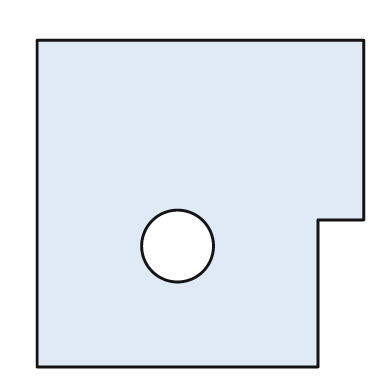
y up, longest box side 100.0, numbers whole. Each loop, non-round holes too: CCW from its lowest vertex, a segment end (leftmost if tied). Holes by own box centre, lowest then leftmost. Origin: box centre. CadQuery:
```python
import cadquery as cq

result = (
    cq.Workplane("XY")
    .moveTo(-50.0, -50.0)
    .lineTo(36.0, -50.0)
    .lineTo(36.0, -5.0)
    .lineTo(50.0, -5.0)
    .lineTo(50.0, 50.0)
    .lineTo(-50.0, 50.0)
    .close()
    .moveTo(-7.0, -13.0)
    .circle(11.0)
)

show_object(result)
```